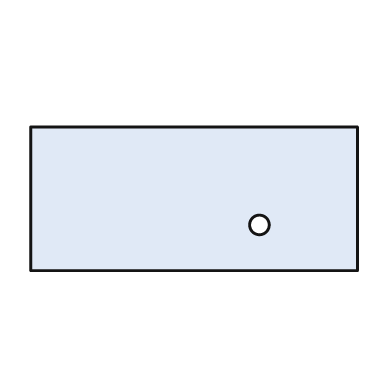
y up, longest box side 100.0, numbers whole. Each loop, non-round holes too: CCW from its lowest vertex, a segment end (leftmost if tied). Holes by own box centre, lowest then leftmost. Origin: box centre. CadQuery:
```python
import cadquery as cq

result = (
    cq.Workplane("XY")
    .moveTo(-50.0, -22.0)
    .lineTo(50.0, -22.0)
    .lineTo(50.0, 22.0)
    .lineTo(-50.0, 22.0)
    .close()
    .moveTo(20.0, -8.0)
    .circle(3.0)
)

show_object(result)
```